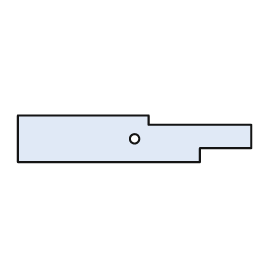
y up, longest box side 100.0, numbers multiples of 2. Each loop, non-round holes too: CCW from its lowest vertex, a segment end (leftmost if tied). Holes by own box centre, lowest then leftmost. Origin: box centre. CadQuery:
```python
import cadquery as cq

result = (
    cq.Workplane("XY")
    .moveTo(-50.0, -10.0)
    .lineTo(28.0, -10.0)
    .lineTo(28.0, -4.0)
    .lineTo(50.0, -4.0)
    .lineTo(50.0, 6.0)
    .lineTo(6.0, 6.0)
    .lineTo(6.0, 10.0)
    .lineTo(-50.0, 10.0)
    .close()
    .moveTo(0.0, 0.0)
    .circle(2.0)
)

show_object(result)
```